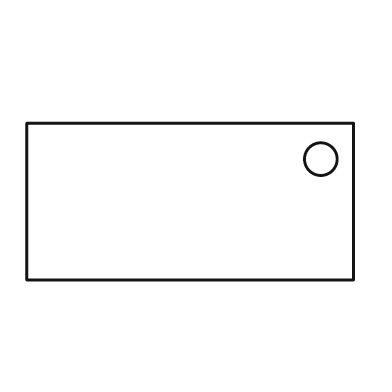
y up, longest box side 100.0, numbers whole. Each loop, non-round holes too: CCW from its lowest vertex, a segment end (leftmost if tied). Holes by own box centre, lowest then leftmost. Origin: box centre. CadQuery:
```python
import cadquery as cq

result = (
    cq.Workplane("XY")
    .moveTo(-50.0, -24.0)
    .lineTo(50.0, -24.0)
    .lineTo(50.0, 24.0)
    .lineTo(-50.0, 24.0)
    .close()
    .moveTo(40.0, 13.0)
    .circle(5.0)
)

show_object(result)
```